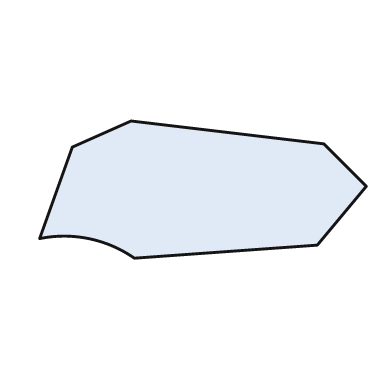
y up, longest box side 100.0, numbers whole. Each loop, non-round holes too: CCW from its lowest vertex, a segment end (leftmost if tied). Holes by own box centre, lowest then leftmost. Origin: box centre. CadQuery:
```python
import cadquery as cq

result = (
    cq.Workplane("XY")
    .moveTo(-21.0, -21.0)
    .lineTo(35.0, -17.0)
    .lineTo(50.0, 1.0)
    .lineTo(37.0, 14.0)
    .lineTo(-22.0, 21.0)
    .lineTo(-40.0, 13.0)
    .lineTo(-50.0, -15.0)
    .threePointArc((-35.0, -15.0), (-21.0, -21.0))
    .close()
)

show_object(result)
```